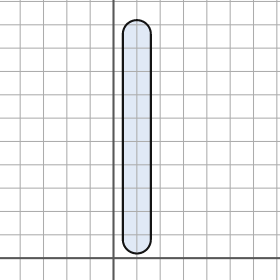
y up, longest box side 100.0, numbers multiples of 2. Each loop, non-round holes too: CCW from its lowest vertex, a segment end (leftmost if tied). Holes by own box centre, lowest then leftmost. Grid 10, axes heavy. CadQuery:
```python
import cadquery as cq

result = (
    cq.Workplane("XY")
    .moveTo(4.0, 8.0)
    .threePointArc((10.0, 2.0), (16.0, 8.0))
    .lineTo(16.0, 96.0)
    .threePointArc((10.0, 102.0), (4.0, 96.0))
    .close()
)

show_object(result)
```